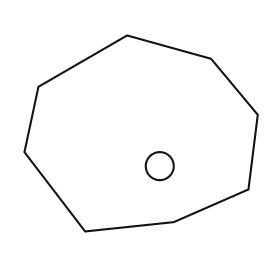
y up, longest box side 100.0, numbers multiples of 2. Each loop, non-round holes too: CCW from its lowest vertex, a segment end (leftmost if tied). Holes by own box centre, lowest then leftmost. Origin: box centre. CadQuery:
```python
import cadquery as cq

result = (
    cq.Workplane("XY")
    .moveTo(-24.0, -42.0)
    .lineTo(14.0, -38.0)
    .lineTo(46.0, -24.0)
    .lineTo(50.0, 8.0)
    .lineTo(30.0, 32.0)
    .lineTo(-6.0, 42.0)
    .lineTo(-44.0, 20.0)
    .lineTo(-50.0, -8.0)
    .close()
    .moveTo(8.0, -14.0)
    .circle(6.0)
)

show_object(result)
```